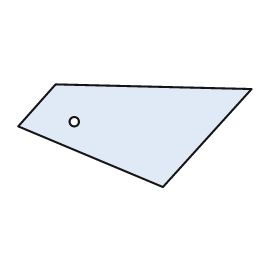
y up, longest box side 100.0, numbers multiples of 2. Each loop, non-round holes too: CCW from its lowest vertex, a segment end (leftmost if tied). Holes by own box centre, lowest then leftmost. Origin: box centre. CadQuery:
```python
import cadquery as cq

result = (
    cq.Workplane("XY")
    .moveTo(12.0, -22.0)
    .lineTo(50.0, 20.0)
    .lineTo(-34.0, 22.0)
    .lineTo(-50.0, 4.0)
    .close()
    .moveTo(-26.0, 6.0)
    .circle(2.0)
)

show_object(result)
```